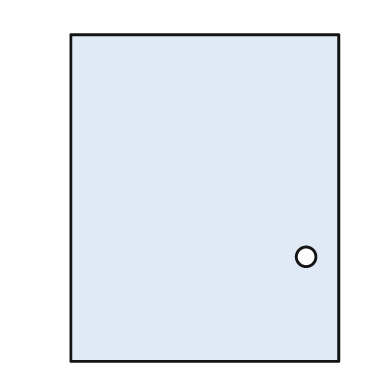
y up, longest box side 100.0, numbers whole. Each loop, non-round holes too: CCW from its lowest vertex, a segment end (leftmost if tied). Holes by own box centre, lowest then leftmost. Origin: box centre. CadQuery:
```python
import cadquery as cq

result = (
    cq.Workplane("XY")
    .moveTo(-41.0, -50.0)
    .lineTo(41.0, -50.0)
    .lineTo(41.0, 50.0)
    .lineTo(-41.0, 50.0)
    .close()
    .moveTo(31.0, -18.0)
    .circle(3.0)
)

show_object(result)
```